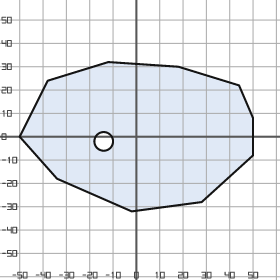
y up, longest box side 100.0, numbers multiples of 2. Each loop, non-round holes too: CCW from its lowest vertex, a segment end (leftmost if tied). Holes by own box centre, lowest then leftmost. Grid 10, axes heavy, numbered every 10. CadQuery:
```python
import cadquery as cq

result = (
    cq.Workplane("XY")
    .moveTo(-2.0, -32.0)
    .lineTo(28.0, -28.0)
    .lineTo(50.0, -8.0)
    .lineTo(50.0, 8.0)
    .lineTo(44.0, 22.0)
    .lineTo(18.0, 30.0)
    .lineTo(-12.0, 32.0)
    .lineTo(-38.0, 24.0)
    .lineTo(-50.0, 0.0)
    .lineTo(-34.0, -18.0)
    .close()
    .moveTo(-14.0, -2.0)
    .circle(4.0)
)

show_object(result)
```